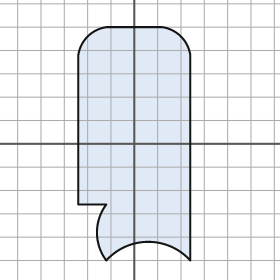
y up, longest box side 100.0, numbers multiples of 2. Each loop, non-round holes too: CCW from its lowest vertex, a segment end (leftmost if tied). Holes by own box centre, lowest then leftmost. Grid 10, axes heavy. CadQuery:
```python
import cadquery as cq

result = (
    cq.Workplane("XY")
    .moveTo(-12.0, -50.0)
    .threePointArc((6.0, -42.0), (24.0, -50.0))
    .lineTo(24.0, 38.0)
    .threePointArc((20.0, 46.0), (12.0, 50.0))
    .lineTo(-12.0, 50.0)
    .threePointArc((-20.0, 46.0), (-24.0, 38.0))
    .lineTo(-24.0, -26.0)
    .lineTo(-12.0, -26.0)
    .threePointArc((-16.0, -38.0), (-12.0, -50.0))
    .close()
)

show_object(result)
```